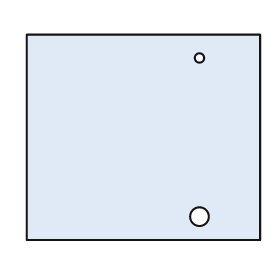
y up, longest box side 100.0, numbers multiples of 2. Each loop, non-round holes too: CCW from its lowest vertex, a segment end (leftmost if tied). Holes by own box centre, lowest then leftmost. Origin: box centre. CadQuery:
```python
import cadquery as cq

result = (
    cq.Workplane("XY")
    .moveTo(-50.0, -44.0)
    .lineTo(50.0, -44.0)
    .lineTo(50.0, 44.0)
    .lineTo(-50.0, 44.0)
    .close()
    .moveTo(24.0, -34.0)
    .circle(4.0)
    .moveTo(24.0, 34.0)
    .circle(2.0)
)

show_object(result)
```